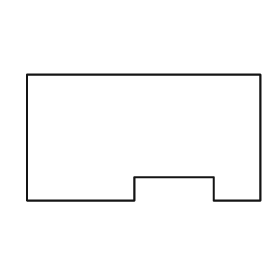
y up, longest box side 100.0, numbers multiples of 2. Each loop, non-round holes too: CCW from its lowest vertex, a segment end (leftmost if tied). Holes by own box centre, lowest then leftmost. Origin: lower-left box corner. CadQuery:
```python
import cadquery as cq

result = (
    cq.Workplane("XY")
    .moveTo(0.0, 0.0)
    .lineTo(46.0, 0.0)
    .lineTo(46.0, 10.0)
    .lineTo(80.0, 10.0)
    .lineTo(80.0, 0.0)
    .lineTo(100.0, 0.0)
    .lineTo(100.0, 54.0)
    .lineTo(0.0, 54.0)
    .close()
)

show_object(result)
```